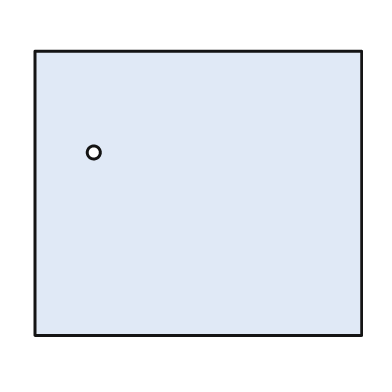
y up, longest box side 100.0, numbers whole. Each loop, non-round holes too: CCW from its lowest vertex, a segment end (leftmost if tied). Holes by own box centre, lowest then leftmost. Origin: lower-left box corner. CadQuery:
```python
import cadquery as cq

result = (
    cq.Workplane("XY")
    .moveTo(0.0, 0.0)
    .lineTo(100.0, 0.0)
    .lineTo(100.0, 87.0)
    .lineTo(0.0, 87.0)
    .close()
    .moveTo(18.0, 56.0)
    .circle(2.0)
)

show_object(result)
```